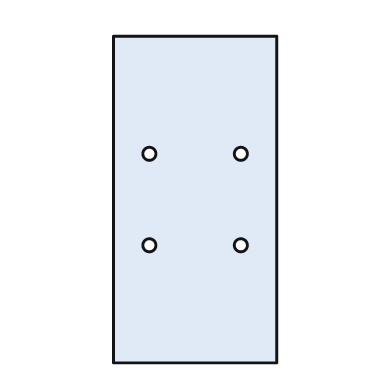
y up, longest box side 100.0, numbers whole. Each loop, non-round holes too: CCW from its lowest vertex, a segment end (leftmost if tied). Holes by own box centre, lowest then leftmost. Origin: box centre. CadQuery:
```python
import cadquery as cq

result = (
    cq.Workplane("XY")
    .moveTo(-25.0, -50.0)
    .lineTo(25.0, -50.0)
    .lineTo(25.0, 50.0)
    .lineTo(-25.0, 50.0)
    .close()
    .moveTo(-14.0, -14.0)
    .circle(2.0)
    .moveTo(14.0, -14.0)
    .circle(2.0)
    .moveTo(-14.0, 14.0)
    .circle(2.0)
    .moveTo(14.0, 14.0)
    .circle(2.0)
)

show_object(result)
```